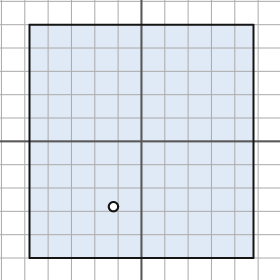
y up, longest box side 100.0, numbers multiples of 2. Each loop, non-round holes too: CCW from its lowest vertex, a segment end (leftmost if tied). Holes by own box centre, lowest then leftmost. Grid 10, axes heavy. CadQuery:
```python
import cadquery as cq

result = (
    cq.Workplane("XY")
    .moveTo(-48.0, -50.0)
    .lineTo(48.0, -50.0)
    .lineTo(48.0, 50.0)
    .lineTo(-48.0, 50.0)
    .close()
    .moveTo(-12.0, -28.0)
    .circle(2.0)
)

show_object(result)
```